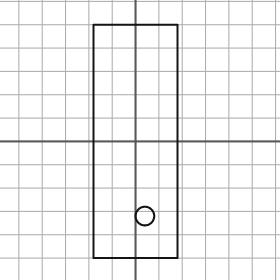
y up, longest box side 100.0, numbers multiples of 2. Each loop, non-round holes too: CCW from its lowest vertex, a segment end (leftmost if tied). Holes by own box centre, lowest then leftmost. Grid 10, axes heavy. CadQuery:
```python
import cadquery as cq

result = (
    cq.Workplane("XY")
    .moveTo(-18.0, -50.0)
    .lineTo(18.0, -50.0)
    .lineTo(18.0, 50.0)
    .lineTo(-18.0, 50.0)
    .close()
    .moveTo(4.0, -32.0)
    .circle(4.0)
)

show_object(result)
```